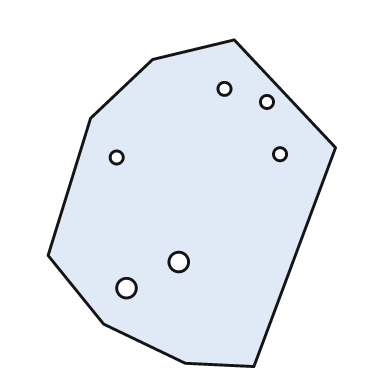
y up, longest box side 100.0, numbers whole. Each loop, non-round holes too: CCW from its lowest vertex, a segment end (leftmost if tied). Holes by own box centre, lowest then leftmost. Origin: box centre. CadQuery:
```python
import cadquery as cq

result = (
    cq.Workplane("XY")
    .moveTo(19.0, -50.0)
    .lineTo(44.0, 17.0)
    .lineTo(13.0, 50.0)
    .lineTo(-12.0, 44.0)
    .lineTo(-31.0, 26.0)
    .lineTo(-44.0, -16.0)
    .lineTo(-27.0, -37.0)
    .lineTo(-2.0, -49.0)
    .close()
    .moveTo(-20.0, -26.0)
    .circle(3.0)
    .moveTo(-4.0, -18.0)
    .circle(3.0)
    .moveTo(-23.0, 14.0)
    .circle(2.0)
    .moveTo(27.0, 15.0)
    .circle(2.0)
    .moveTo(23.0, 31.0)
    .circle(2.0)
    .moveTo(10.0, 35.0)
    .circle(2.0)
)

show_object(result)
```